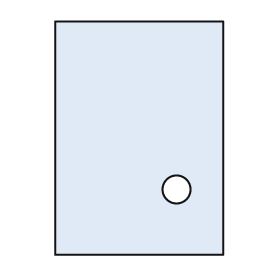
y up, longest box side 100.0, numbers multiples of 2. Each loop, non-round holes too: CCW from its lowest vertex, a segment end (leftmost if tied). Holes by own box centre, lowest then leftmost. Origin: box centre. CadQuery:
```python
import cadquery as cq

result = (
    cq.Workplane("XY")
    .moveTo(-36.0, -50.0)
    .lineTo(36.0, -50.0)
    .lineTo(36.0, 50.0)
    .lineTo(-36.0, 50.0)
    .close()
    .moveTo(16.0, -22.0)
    .circle(6.0)
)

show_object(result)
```